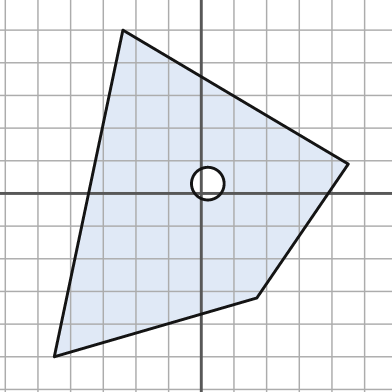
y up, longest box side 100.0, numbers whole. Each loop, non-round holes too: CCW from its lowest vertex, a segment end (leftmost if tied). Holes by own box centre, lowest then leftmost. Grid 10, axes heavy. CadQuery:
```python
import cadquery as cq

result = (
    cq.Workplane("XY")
    .moveTo(-45.0, -50.0)
    .lineTo(17.0, -32.0)
    .lineTo(45.0, 9.0)
    .lineTo(-24.0, 50.0)
    .close()
    .moveTo(2.0, 3.0)
    .circle(5.0)
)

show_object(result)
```